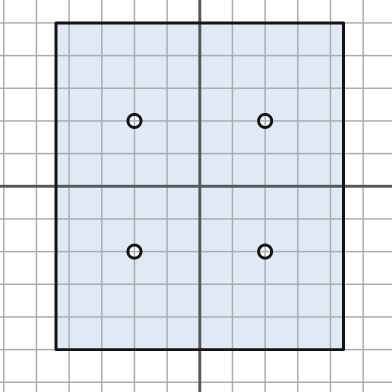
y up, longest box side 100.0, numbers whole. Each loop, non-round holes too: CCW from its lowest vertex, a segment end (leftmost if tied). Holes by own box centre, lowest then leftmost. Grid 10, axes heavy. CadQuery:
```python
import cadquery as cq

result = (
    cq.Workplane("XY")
    .moveTo(-44.0, -50.0)
    .lineTo(44.0, -50.0)
    .lineTo(44.0, 50.0)
    .lineTo(-44.0, 50.0)
    .close()
    .moveTo(-20.0, -20.0)
    .circle(2.0)
    .moveTo(20.0, -20.0)
    .circle(2.0)
    .moveTo(-20.0, 20.0)
    .circle(2.0)
    .moveTo(20.0, 20.0)
    .circle(2.0)
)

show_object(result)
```